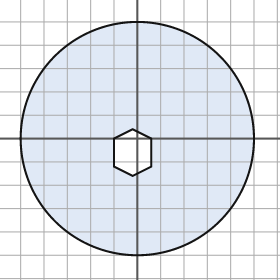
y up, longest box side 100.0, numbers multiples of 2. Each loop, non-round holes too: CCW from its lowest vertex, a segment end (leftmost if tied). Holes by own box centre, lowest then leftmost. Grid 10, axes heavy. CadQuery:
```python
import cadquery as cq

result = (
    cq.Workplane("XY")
    .moveTo(0.0, 0.0)
    .circle(50.0)
    .moveTo(-2.0, -16.0)
    .lineTo(6.0, -12.0)
    .lineTo(6.0, 0.0)
    .lineTo(-2.0, 4.0)
    .lineTo(-10.0, 0.0)
    .lineTo(-10.0, -12.0)
    .close()
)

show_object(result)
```